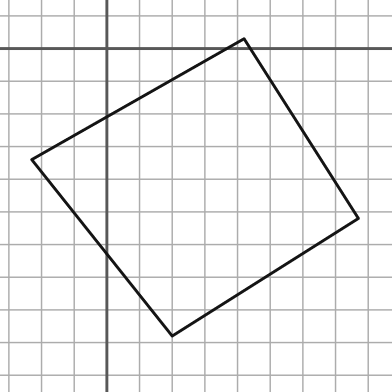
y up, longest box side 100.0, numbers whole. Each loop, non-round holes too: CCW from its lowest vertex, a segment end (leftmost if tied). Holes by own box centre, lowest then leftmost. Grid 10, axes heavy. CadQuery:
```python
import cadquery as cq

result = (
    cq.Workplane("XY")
    .moveTo(20.0, -88.0)
    .lineTo(77.0, -52.0)
    .lineTo(42.0, 3.0)
    .lineTo(-23.0, -34.0)
    .close()
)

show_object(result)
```